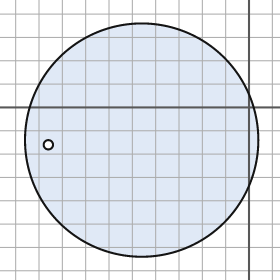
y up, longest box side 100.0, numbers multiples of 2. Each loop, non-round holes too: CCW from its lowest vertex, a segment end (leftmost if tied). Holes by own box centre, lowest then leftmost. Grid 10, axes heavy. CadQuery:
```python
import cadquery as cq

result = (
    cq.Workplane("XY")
    .moveTo(-46.0, -14.0)
    .circle(50.0)
    .moveTo(-86.0, -16.0)
    .circle(2.0)
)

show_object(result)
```